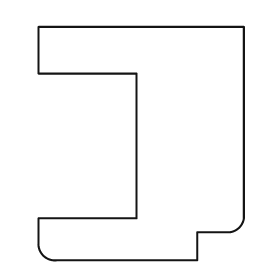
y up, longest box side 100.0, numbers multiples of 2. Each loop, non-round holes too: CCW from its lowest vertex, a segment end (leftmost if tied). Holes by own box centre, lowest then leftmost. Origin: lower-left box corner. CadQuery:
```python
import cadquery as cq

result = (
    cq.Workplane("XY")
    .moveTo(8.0, 0.0)
    .lineTo(68.0, 0.0)
    .lineTo(68.0, 12.0)
    .lineTo(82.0, 12.0)
    .threePointArc((86.0, 14.0), (88.0, 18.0))
    .lineTo(88.0, 100.0)
    .lineTo(0.0, 100.0)
    .lineTo(0.0, 80.0)
    .lineTo(42.0, 80.0)
    .lineTo(42.0, 18.0)
    .lineTo(0.0, 18.0)
    .lineTo(0.0, 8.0)
    .threePointArc((2.0, 2.0), (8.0, 0.0))
    .close()
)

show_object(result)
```